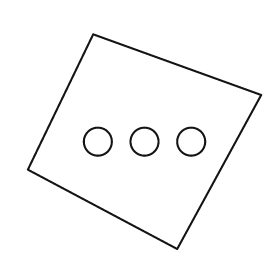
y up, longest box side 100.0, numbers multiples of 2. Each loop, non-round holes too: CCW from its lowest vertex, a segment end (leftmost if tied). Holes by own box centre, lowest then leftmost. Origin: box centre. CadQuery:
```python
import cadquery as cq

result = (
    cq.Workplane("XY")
    .moveTo(14.0, -46.0)
    .lineTo(50.0, 20.0)
    .lineTo(-22.0, 46.0)
    .lineTo(-50.0, -12.0)
    .close()
    .moveTo(-20.0, 0.0)
    .circle(6.0)
    .moveTo(0.0, 0.0)
    .circle(6.0)
    .moveTo(20.0, 0.0)
    .circle(6.0)
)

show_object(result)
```